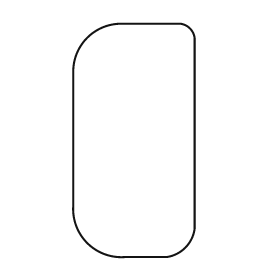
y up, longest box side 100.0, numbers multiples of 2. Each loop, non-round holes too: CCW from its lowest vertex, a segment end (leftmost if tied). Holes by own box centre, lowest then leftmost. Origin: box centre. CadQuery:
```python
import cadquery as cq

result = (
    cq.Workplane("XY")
    .moveTo(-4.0, -50.0)
    .lineTo(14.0, -50.0)
    .threePointArc((22.0, -46.0), (26.0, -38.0))
    .lineTo(26.0, 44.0)
    .threePointArc((24.0, 48.0), (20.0, 50.0))
    .lineTo(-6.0, 50.0)
    .threePointArc((-20.0, 44.0), (-26.0, 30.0))
    .lineTo(-26.0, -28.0)
    .threePointArc((-20.0, -44.0), (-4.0, -50.0))
    .close()
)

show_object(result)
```